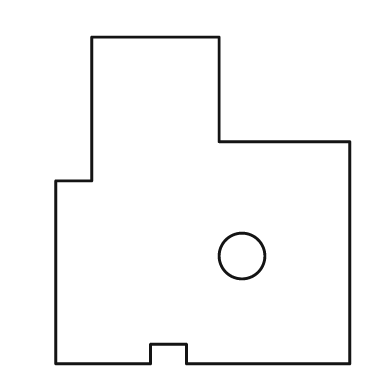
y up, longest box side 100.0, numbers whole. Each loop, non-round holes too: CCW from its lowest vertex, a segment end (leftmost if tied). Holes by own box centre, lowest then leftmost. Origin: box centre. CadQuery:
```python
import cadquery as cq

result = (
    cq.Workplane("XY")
    .moveTo(-45.0, -50.0)
    .lineTo(-16.0, -50.0)
    .lineTo(-16.0, -44.0)
    .lineTo(-5.0, -44.0)
    .lineTo(-5.0, -50.0)
    .lineTo(45.0, -50.0)
    .lineTo(45.0, 18.0)
    .lineTo(5.0, 18.0)
    .lineTo(5.0, 50.0)
    .lineTo(-34.0, 50.0)
    .lineTo(-34.0, 6.0)
    .lineTo(-45.0, 6.0)
    .close()
    .moveTo(12.0, -17.0)
    .circle(7.0)
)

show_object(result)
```